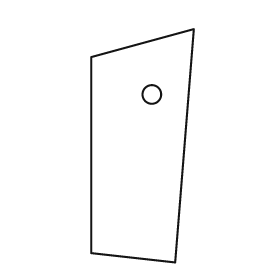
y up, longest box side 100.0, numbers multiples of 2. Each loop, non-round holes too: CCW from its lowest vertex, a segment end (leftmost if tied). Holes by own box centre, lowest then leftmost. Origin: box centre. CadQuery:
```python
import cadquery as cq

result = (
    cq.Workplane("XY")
    .moveTo(14.0, -50.0)
    .lineTo(22.0, 50.0)
    .lineTo(-22.0, 38.0)
    .lineTo(-22.0, -46.0)
    .close()
    .moveTo(4.0, 22.0)
    .circle(4.0)
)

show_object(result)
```